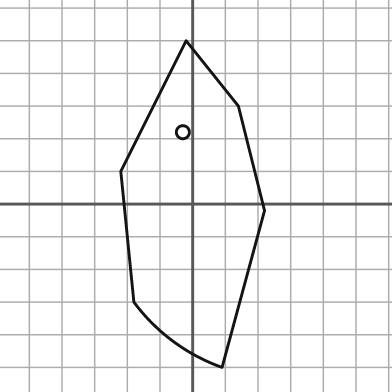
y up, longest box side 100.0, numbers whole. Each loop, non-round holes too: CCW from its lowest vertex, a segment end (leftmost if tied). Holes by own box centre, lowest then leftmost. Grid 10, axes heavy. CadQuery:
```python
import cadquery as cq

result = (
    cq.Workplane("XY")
    .moveTo(9.0, -50.0)
    .lineTo(22.0, -2.0)
    .lineTo(14.0, 30.0)
    .lineTo(-2.0, 50.0)
    .lineTo(-22.0, 10.0)
    .lineTo(-18.0, -30.0)
    .threePointArc((-6.0, -42.0), (9.0, -50.0))
    .close()
    .moveTo(-3.0, 22.0)
    .circle(2.0)
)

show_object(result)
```